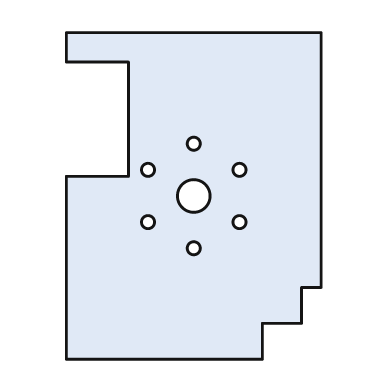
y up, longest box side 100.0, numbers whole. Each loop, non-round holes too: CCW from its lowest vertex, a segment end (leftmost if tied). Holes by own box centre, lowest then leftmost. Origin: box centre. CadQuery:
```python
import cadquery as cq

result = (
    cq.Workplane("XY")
    .moveTo(-39.0, -50.0)
    .lineTo(21.0, -50.0)
    .lineTo(21.0, -39.0)
    .lineTo(33.0, -39.0)
    .lineTo(33.0, -28.0)
    .lineTo(39.0, -28.0)
    .lineTo(39.0, 50.0)
    .lineTo(-39.0, 50.0)
    .lineTo(-39.0, 41.0)
    .lineTo(-20.0, 41.0)
    .lineTo(-20.0, 6.0)
    .lineTo(-39.0, 6.0)
    .close()
    .moveTo(0.0, -16.0)
    .circle(2.0)
    .moveTo(-14.0, -8.0)
    .circle(2.0)
    .moveTo(14.0, -8.0)
    .circle(2.0)
    .moveTo(0.0, 0.0)
    .circle(5.0)
    .moveTo(-14.0, 8.0)
    .circle(2.0)
    .moveTo(14.0, 8.0)
    .circle(2.0)
    .moveTo(0.0, 16.0)
    .circle(2.0)
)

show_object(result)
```